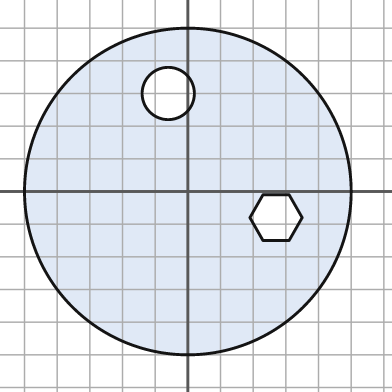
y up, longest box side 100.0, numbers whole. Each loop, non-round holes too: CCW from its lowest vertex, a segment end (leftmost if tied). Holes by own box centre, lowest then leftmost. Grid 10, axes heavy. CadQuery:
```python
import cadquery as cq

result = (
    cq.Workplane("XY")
    .moveTo(0.0, 0.0)
    .circle(50.0)
    .moveTo(23.0, -15.0)
    .lineTo(31.0, -15.0)
    .lineTo(35.0, -8.0)
    .lineTo(31.0, -1.0)
    .lineTo(23.0, -1.0)
    .lineTo(19.0, -8.0)
    .close()
    .moveTo(-6.0, 30.0)
    .circle(8.0)
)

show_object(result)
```